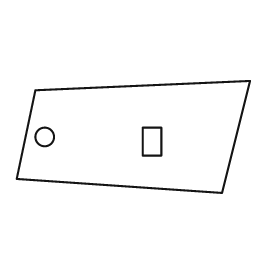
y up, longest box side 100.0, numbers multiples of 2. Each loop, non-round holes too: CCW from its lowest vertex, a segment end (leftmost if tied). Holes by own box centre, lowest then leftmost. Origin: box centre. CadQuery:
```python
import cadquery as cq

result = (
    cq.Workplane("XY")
    .moveTo(38.0, -24.0)
    .lineTo(50.0, 24.0)
    .lineTo(-42.0, 20.0)
    .lineTo(-50.0, -18.0)
    .close()
    .moveTo(4.0, -8.0)
    .lineTo(12.0, -8.0)
    .lineTo(12.0, 4.0)
    .lineTo(4.0, 4.0)
    .close()
    .moveTo(-38.0, 0.0)
    .circle(4.0)
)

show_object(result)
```